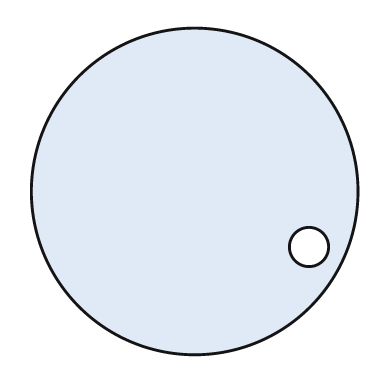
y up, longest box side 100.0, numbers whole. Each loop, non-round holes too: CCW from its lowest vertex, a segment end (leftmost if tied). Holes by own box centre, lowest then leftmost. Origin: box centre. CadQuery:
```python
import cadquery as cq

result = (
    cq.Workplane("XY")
    .moveTo(0.0, 0.0)
    .circle(50.0)
    .moveTo(35.0, -17.0)
    .circle(6.0)
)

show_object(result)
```